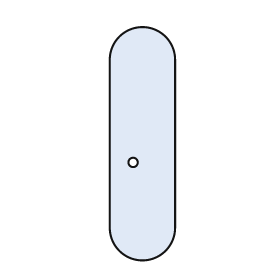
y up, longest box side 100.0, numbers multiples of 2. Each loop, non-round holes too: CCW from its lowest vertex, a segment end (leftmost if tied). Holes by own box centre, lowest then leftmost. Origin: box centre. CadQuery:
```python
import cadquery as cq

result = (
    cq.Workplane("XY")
    .moveTo(-14.0, -36.0)
    .threePointArc((0.0, -50.0), (14.0, -36.0))
    .lineTo(14.0, 36.0)
    .threePointArc((0.0, 50.0), (-14.0, 36.0))
    .close()
    .moveTo(-4.0, -8.0)
    .circle(2.0)
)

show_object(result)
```